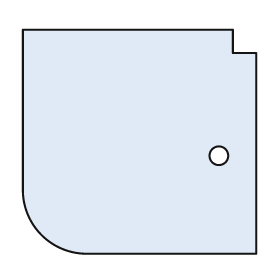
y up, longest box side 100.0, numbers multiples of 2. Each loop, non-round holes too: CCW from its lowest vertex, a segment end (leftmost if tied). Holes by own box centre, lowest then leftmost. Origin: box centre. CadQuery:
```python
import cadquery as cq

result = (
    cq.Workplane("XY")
    .moveTo(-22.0, -48.0)
    .lineTo(50.0, -48.0)
    .lineTo(50.0, 38.0)
    .lineTo(40.0, 38.0)
    .lineTo(40.0, 48.0)
    .lineTo(-50.0, 48.0)
    .lineTo(-50.0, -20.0)
    .threePointArc((-42.0, -40.0), (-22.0, -48.0))
    .close()
    .moveTo(34.0, -6.0)
    .circle(4.0)
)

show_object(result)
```